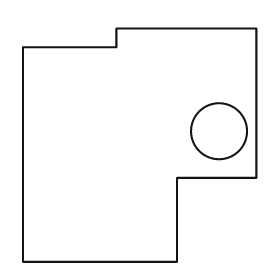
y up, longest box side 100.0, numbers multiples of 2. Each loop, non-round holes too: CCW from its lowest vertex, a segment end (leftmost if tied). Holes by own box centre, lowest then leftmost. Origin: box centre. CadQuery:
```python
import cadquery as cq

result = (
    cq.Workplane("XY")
    .moveTo(-50.0, -50.0)
    .lineTo(16.0, -50.0)
    .lineTo(16.0, -14.0)
    .lineTo(50.0, -14.0)
    .lineTo(50.0, 50.0)
    .lineTo(-10.0, 50.0)
    .lineTo(-10.0, 42.0)
    .lineTo(-50.0, 42.0)
    .close()
    .moveTo(34.0, 6.0)
    .circle(12.0)
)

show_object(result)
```